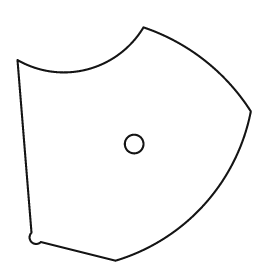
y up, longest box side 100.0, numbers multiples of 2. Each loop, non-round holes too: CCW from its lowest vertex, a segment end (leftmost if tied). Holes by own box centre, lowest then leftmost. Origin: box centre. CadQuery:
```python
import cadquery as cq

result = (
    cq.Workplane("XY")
    .moveTo(-8.0, -50.0)
    .threePointArc((30.0, -26.0), (50.0, 14.0))
    .threePointArc((30.0, 36.0), (4.0, 50.0))
    .threePointArc((-20.0, 32.0), (-50.0, 36.0))
    .lineTo(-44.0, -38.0)
    .threePointArc((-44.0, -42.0), (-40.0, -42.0))
    .close()
    .moveTo(0.0, 0.0)
    .circle(4.0)
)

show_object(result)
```